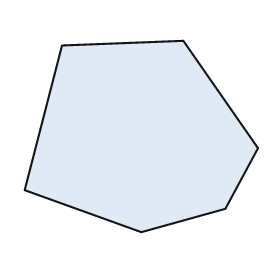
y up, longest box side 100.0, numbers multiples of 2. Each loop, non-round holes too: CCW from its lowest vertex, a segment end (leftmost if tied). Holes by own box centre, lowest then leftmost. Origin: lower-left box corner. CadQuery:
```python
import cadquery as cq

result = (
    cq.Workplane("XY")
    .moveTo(50.0, 0.0)
    .lineTo(86.0, 10.0)
    .lineTo(100.0, 36.0)
    .lineTo(68.0, 82.0)
    .lineTo(16.0, 80.0)
    .lineTo(0.0, 18.0)
    .close()
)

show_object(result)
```